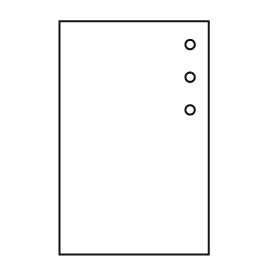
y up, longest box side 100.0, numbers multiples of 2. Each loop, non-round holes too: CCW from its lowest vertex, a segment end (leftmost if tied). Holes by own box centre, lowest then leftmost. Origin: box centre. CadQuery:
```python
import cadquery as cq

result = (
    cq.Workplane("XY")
    .moveTo(-32.0, -50.0)
    .lineTo(32.0, -50.0)
    .lineTo(32.0, 50.0)
    .lineTo(-32.0, 50.0)
    .close()
    .moveTo(24.0, 12.0)
    .circle(2.0)
    .moveTo(24.0, 26.0)
    .circle(2.0)
    .moveTo(24.0, 40.0)
    .circle(2.0)
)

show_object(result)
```